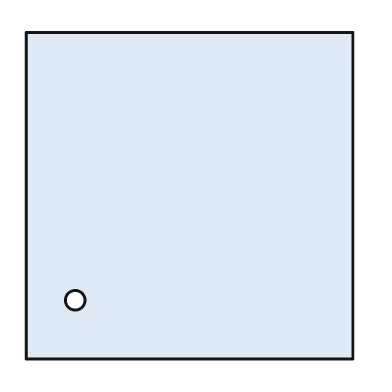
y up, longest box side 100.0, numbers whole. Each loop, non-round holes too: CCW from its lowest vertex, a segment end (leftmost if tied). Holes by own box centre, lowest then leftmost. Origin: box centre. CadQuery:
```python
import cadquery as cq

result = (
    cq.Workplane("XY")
    .moveTo(-50.0, -50.0)
    .lineTo(50.0, -50.0)
    .lineTo(50.0, 50.0)
    .lineTo(-50.0, 50.0)
    .close()
    .moveTo(-35.0, -32.0)
    .circle(3.0)
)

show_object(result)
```